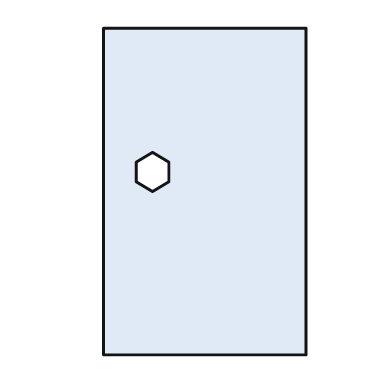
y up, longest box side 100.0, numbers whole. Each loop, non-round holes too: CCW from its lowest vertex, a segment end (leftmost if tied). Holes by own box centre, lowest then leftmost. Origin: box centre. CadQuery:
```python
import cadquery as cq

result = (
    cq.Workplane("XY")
    .moveTo(-31.0, -50.0)
    .lineTo(31.0, -50.0)
    .lineTo(31.0, 50.0)
    .lineTo(-31.0, 50.0)
    .close()
    .moveTo(-16.0, 0.0)
    .lineTo(-11.0, 3.0)
    .lineTo(-11.0, 9.0)
    .lineTo(-16.0, 12.0)
    .lineTo(-21.0, 9.0)
    .lineTo(-21.0, 3.0)
    .close()
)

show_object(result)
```